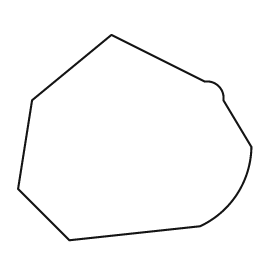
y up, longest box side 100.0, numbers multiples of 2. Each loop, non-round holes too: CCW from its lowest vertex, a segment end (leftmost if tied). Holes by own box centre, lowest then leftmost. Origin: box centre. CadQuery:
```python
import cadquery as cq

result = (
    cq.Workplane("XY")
    .moveTo(-28.0, -44.0)
    .lineTo(28.0, -38.0)
    .threePointArc((44.0, -24.0), (50.0, -4.0))
    .lineTo(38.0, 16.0)
    .threePointArc((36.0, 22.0), (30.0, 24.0))
    .lineTo(-10.0, 44.0)
    .lineTo(-44.0, 16.0)
    .lineTo(-50.0, -22.0)
    .close()
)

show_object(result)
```